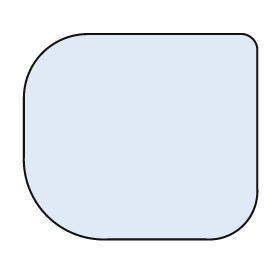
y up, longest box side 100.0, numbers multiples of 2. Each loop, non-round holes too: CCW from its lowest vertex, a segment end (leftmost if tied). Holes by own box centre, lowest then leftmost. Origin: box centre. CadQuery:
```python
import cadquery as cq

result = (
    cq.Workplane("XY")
    .moveTo(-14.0, -44.0)
    .lineTo(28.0, -44.0)
    .threePointArc((44.0, -38.0), (50.0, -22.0))
    .lineTo(50.0, 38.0)
    .threePointArc((48.0, 42.0), (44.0, 44.0))
    .lineTo(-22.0, 44.0)
    .threePointArc((-42.0, 36.0), (-50.0, 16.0))
    .lineTo(-50.0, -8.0)
    .threePointArc((-40.0, -34.0), (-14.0, -44.0))
    .close()
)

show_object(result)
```